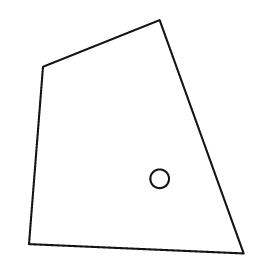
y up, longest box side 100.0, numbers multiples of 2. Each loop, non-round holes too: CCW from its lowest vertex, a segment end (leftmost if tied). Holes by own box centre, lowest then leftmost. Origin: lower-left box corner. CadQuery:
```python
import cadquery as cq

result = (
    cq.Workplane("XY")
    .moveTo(92.0, 0.0)
    .lineTo(56.0, 100.0)
    .lineTo(6.0, 80.0)
    .lineTo(0.0, 4.0)
    .close()
    .moveTo(56.0, 32.0)
    .circle(4.0)
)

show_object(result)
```